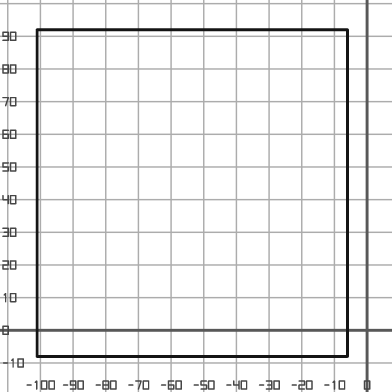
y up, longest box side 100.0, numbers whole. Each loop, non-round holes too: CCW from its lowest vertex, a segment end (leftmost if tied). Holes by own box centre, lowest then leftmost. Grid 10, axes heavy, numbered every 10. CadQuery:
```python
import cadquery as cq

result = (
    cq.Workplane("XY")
    .moveTo(-101.0, -8.0)
    .lineTo(-6.0, -8.0)
    .lineTo(-6.0, 92.0)
    .lineTo(-101.0, 92.0)
    .close()
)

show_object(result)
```